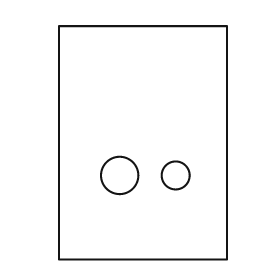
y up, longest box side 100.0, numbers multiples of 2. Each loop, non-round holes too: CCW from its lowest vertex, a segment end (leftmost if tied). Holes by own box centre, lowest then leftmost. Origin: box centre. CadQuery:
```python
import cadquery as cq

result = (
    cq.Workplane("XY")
    .moveTo(-36.0, -50.0)
    .lineTo(36.0, -50.0)
    .lineTo(36.0, 50.0)
    .lineTo(-36.0, 50.0)
    .close()
    .moveTo(-10.0, -14.0)
    .circle(8.0)
    .moveTo(14.0, -14.0)
    .circle(6.0)
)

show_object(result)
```